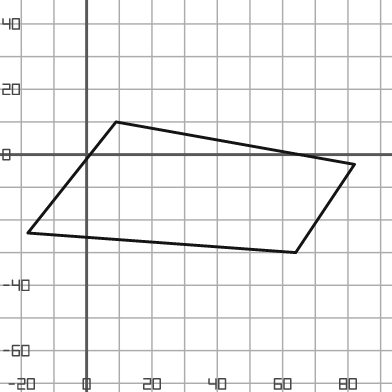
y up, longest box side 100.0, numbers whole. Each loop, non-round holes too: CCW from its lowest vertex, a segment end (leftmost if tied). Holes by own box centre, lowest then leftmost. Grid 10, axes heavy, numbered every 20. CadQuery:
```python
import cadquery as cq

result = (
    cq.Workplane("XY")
    .moveTo(64.0, -30.0)
    .lineTo(82.0, -3.0)
    .lineTo(9.0, 10.0)
    .lineTo(-18.0, -24.0)
    .close()
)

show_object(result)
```